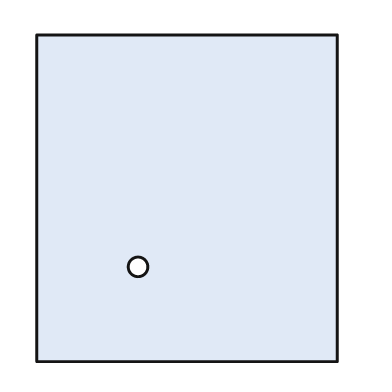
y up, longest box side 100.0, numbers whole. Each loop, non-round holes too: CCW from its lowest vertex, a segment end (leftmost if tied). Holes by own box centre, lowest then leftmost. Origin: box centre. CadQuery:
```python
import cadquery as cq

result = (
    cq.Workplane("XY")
    .moveTo(-46.0, -50.0)
    .lineTo(46.0, -50.0)
    .lineTo(46.0, 50.0)
    .lineTo(-46.0, 50.0)
    .close()
    .moveTo(-15.0, -21.0)
    .circle(3.0)
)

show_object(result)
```